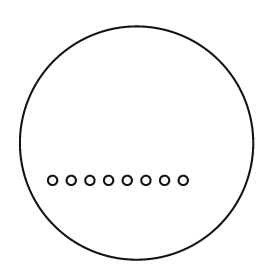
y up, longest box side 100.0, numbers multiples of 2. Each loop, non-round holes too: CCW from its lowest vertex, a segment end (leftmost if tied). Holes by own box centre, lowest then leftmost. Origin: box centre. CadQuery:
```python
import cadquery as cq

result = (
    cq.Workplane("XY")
    .moveTo(0.0, 0.0)
    .circle(50.0)
    .moveTo(-36.0, -16.0)
    .circle(2.0)
    .moveTo(-28.0, -16.0)
    .circle(2.0)
    .moveTo(-20.0, -16.0)
    .circle(2.0)
    .moveTo(-12.0, -16.0)
    .circle(2.0)
    .moveTo(-4.0, -16.0)
    .circle(2.0)
    .moveTo(4.0, -16.0)
    .circle(2.0)
    .moveTo(12.0, -16.0)
    .circle(2.0)
    .moveTo(20.0, -16.0)
    .circle(2.0)
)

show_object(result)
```